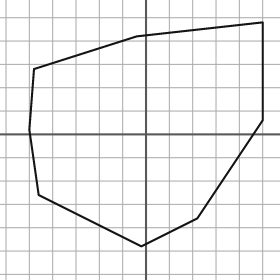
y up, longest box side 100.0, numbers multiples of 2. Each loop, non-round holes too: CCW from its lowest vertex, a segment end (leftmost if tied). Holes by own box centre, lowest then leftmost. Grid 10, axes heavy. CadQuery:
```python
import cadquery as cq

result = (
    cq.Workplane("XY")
    .moveTo(-2.0, -48.0)
    .lineTo(22.0, -36.0)
    .lineTo(50.0, 6.0)
    .lineTo(50.0, 48.0)
    .lineTo(-4.0, 42.0)
    .lineTo(-48.0, 28.0)
    .lineTo(-50.0, 2.0)
    .lineTo(-46.0, -26.0)
    .close()
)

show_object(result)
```